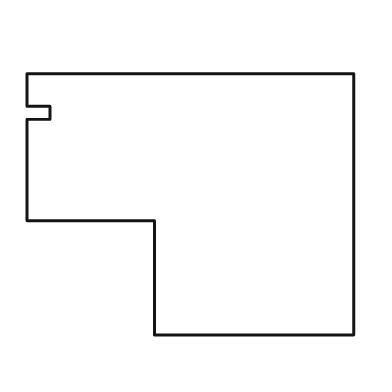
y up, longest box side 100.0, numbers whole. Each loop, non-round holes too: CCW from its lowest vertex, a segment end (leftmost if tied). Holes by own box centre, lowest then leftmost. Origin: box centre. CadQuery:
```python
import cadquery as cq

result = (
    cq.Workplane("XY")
    .moveTo(-11.0, -40.0)
    .lineTo(50.0, -40.0)
    .lineTo(50.0, 40.0)
    .lineTo(-50.0, 40.0)
    .lineTo(-50.0, 30.0)
    .lineTo(-43.0, 30.0)
    .lineTo(-43.0, 26.0)
    .lineTo(-50.0, 26.0)
    .lineTo(-50.0, -5.0)
    .lineTo(-11.0, -5.0)
    .close()
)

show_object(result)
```